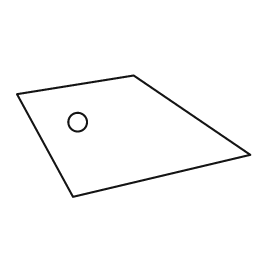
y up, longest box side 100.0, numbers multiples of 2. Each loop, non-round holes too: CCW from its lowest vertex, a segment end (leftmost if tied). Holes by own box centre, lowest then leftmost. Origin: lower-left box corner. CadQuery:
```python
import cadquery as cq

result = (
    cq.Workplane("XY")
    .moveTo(24.0, 0.0)
    .lineTo(100.0, 18.0)
    .lineTo(50.0, 52.0)
    .lineTo(0.0, 44.0)
    .close()
    .moveTo(26.0, 32.0)
    .circle(4.0)
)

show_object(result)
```